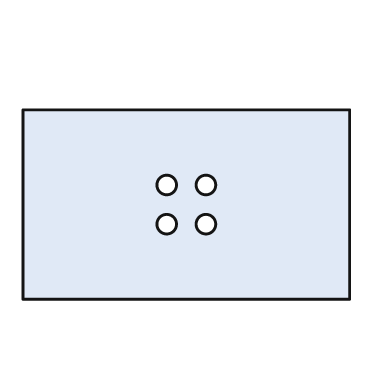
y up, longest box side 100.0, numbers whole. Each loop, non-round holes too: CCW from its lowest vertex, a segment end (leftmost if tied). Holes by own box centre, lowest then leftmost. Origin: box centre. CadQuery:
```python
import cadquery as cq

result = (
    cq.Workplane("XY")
    .moveTo(-50.0, -29.0)
    .lineTo(50.0, -29.0)
    .lineTo(50.0, 29.0)
    .lineTo(-50.0, 29.0)
    .close()
    .moveTo(-6.0, -6.0)
    .circle(3.0)
    .moveTo(6.0, -6.0)
    .circle(3.0)
    .moveTo(-6.0, 6.0)
    .circle(3.0)
    .moveTo(6.0, 6.0)
    .circle(3.0)
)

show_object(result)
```